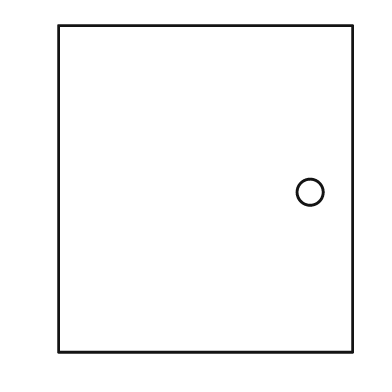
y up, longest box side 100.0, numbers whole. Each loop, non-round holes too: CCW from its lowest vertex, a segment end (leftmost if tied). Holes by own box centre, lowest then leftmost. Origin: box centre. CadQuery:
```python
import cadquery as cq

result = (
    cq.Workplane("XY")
    .moveTo(-45.0, -50.0)
    .lineTo(45.0, -50.0)
    .lineTo(45.0, 50.0)
    .lineTo(-45.0, 50.0)
    .close()
    .moveTo(32.0, -1.0)
    .circle(4.0)
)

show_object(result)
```